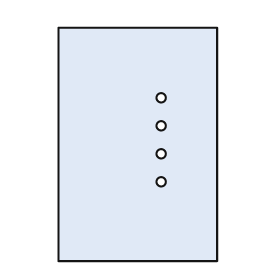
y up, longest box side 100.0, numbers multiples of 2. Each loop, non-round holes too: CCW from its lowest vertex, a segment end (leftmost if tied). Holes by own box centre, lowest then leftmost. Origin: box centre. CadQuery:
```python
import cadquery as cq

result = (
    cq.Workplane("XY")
    .moveTo(-34.0, -50.0)
    .lineTo(34.0, -50.0)
    .lineTo(34.0, 50.0)
    .lineTo(-34.0, 50.0)
    .close()
    .moveTo(10.0, -16.0)
    .circle(2.0)
    .moveTo(10.0, -4.0)
    .circle(2.0)
    .moveTo(10.0, 8.0)
    .circle(2.0)
    .moveTo(10.0, 20.0)
    .circle(2.0)
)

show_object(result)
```